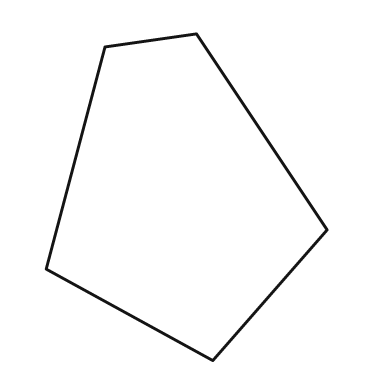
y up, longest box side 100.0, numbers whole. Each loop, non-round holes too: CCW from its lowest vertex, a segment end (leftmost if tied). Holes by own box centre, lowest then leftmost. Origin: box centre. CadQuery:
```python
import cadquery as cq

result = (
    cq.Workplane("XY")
    .moveTo(8.0, -50.0)
    .lineTo(43.0, -10.0)
    .lineTo(3.0, 50.0)
    .lineTo(-25.0, 46.0)
    .lineTo(-43.0, -22.0)
    .close()
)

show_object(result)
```